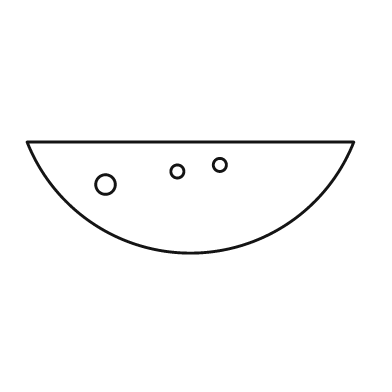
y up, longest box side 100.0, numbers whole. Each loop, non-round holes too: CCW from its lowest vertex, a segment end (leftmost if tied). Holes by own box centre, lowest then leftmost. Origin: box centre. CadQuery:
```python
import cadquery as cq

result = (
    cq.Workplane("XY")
    .moveTo(-50.0, 17.0)
    .threePointArc((0.0, -17.0), (50.0, 17.0))
    .close()
    .moveTo(-26.0, 4.0)
    .circle(3.0)
    .moveTo(-4.0, 8.0)
    .circle(2.0)
    .moveTo(9.0, 10.0)
    .circle(2.0)
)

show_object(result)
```